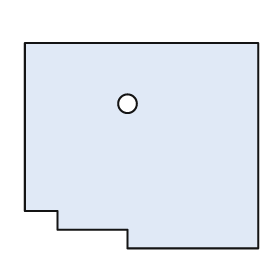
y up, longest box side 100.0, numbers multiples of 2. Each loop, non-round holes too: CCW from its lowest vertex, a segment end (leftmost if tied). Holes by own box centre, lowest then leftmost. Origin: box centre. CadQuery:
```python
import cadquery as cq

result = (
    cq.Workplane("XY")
    .moveTo(-6.0, -44.0)
    .lineTo(50.0, -44.0)
    .lineTo(50.0, 44.0)
    .lineTo(-50.0, 44.0)
    .lineTo(-50.0, -28.0)
    .lineTo(-36.0, -28.0)
    .lineTo(-36.0, -36.0)
    .lineTo(-6.0, -36.0)
    .close()
    .moveTo(-6.0, 18.0)
    .circle(4.0)
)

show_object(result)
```